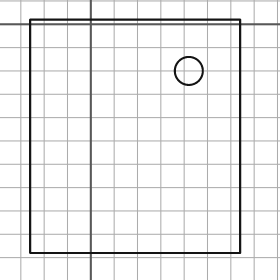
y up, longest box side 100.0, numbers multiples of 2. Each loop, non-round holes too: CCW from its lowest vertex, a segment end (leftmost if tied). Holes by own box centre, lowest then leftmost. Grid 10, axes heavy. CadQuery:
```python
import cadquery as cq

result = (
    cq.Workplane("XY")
    .moveTo(-26.0, -98.0)
    .lineTo(64.0, -98.0)
    .lineTo(64.0, 2.0)
    .lineTo(-26.0, 2.0)
    .close()
    .moveTo(42.0, -20.0)
    .circle(6.0)
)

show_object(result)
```